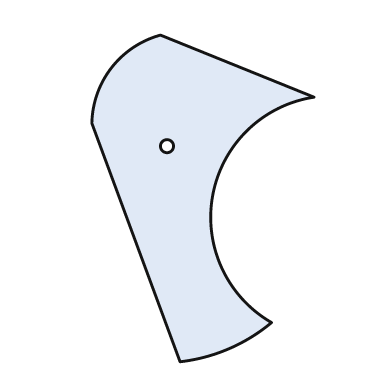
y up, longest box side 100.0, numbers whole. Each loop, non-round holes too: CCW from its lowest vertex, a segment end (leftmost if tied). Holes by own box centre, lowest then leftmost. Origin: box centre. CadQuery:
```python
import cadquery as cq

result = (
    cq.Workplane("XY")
    .moveTo(-7.0, -50.0)
    .threePointArc((8.0, -46.0), (21.0, -38.0))
    .threePointArc((3.0, 1.0), (34.0, 31.0))
    .lineTo(-13.0, 50.0)
    .threePointArc((-28.0, 40.0), (-34.0, 23.0))
    .close()
    .moveTo(-11.0, 16.0)
    .circle(2.0)
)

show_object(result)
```